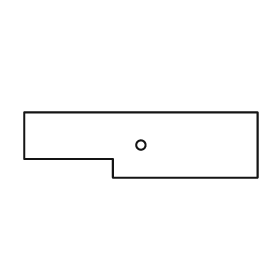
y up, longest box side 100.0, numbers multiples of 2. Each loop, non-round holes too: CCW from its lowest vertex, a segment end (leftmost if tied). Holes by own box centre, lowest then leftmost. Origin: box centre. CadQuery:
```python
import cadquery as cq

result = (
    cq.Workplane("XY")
    .moveTo(-12.0, -14.0)
    .lineTo(50.0, -14.0)
    .lineTo(50.0, 14.0)
    .lineTo(-50.0, 14.0)
    .lineTo(-50.0, -6.0)
    .lineTo(-12.0, -6.0)
    .close()
    .moveTo(0.0, 0.0)
    .circle(2.0)
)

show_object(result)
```